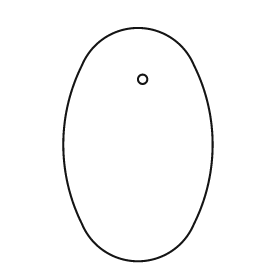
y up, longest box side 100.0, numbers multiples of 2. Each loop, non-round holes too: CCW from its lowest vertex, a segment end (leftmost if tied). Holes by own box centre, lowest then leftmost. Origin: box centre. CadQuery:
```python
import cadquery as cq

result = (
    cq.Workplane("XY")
    .moveTo(-24.0, -34.0)
    .threePointArc((0.0, -50.0), (24.0, -34.0))
    .threePointArc((32.0, 0.0), (24.0, 34.0))
    .threePointArc((0.0, 50.0), (-24.0, 34.0))
    .threePointArc((-32.0, 0.0), (-24.0, -34.0))
    .close()
    .moveTo(2.0, 28.0)
    .circle(2.0)
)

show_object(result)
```